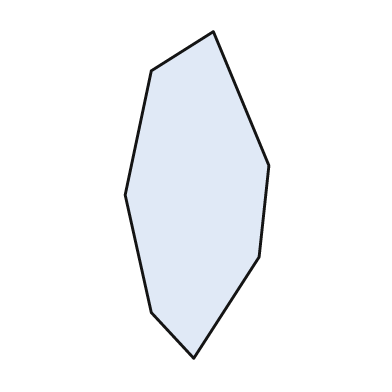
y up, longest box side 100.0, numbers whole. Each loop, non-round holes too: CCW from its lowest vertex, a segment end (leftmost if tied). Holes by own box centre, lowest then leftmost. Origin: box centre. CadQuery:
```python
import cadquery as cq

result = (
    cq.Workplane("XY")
    .moveTo(-1.0, -50.0)
    .lineTo(19.0, -19.0)
    .lineTo(22.0, 9.0)
    .lineTo(5.0, 50.0)
    .lineTo(-14.0, 38.0)
    .lineTo(-22.0, 0.0)
    .lineTo(-14.0, -36.0)
    .close()
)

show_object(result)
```